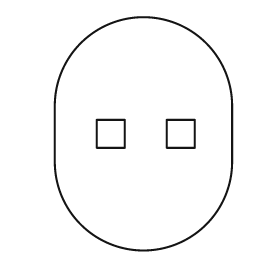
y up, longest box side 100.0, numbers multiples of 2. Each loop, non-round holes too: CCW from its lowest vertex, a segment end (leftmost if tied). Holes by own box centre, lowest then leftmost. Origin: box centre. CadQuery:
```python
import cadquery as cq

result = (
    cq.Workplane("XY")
    .moveTo(-38.0, -12.0)
    .threePointArc((0.0, -50.0), (38.0, -12.0))
    .lineTo(38.0, 12.0)
    .threePointArc((0.0, 50.0), (-38.0, 12.0))
    .close()
    .moveTo(-20.0, -6.0)
    .lineTo(-8.0, -6.0)
    .lineTo(-8.0, 6.0)
    .lineTo(-20.0, 6.0)
    .close()
    .moveTo(10.0, -6.0)
    .lineTo(22.0, -6.0)
    .lineTo(22.0, 6.0)
    .lineTo(10.0, 6.0)
    .close()
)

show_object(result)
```